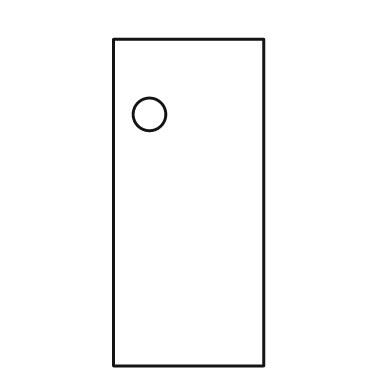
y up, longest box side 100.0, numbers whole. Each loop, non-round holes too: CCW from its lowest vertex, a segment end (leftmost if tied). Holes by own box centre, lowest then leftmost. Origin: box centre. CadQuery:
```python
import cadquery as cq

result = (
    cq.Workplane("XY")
    .moveTo(-23.0, -50.0)
    .lineTo(23.0, -50.0)
    .lineTo(23.0, 50.0)
    .lineTo(-23.0, 50.0)
    .close()
    .moveTo(-12.0, 27.0)
    .circle(5.0)
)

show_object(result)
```